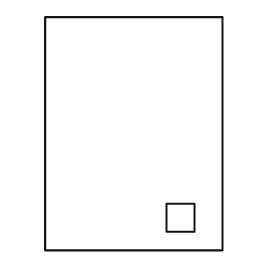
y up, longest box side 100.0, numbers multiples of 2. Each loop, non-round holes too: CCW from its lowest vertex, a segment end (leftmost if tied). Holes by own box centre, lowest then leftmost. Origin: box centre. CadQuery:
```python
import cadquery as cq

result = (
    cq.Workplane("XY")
    .moveTo(-38.0, -50.0)
    .lineTo(38.0, -50.0)
    .lineTo(38.0, 50.0)
    .lineTo(-38.0, 50.0)
    .close()
    .moveTo(14.0, -42.0)
    .lineTo(26.0, -42.0)
    .lineTo(26.0, -30.0)
    .lineTo(14.0, -30.0)
    .close()
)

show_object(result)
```